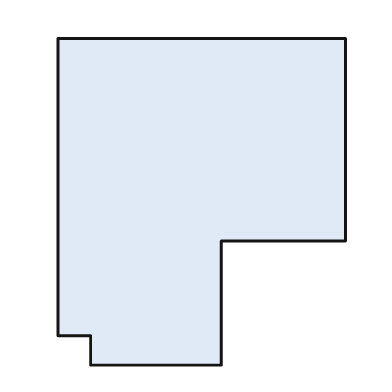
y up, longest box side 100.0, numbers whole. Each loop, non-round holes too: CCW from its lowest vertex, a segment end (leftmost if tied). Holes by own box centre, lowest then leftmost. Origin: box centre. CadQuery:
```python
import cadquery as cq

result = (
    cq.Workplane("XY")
    .moveTo(-34.0, -50.0)
    .lineTo(6.0, -50.0)
    .lineTo(6.0, -12.0)
    .lineTo(44.0, -12.0)
    .lineTo(44.0, 50.0)
    .lineTo(-44.0, 50.0)
    .lineTo(-44.0, -41.0)
    .lineTo(-34.0, -41.0)
    .close()
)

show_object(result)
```